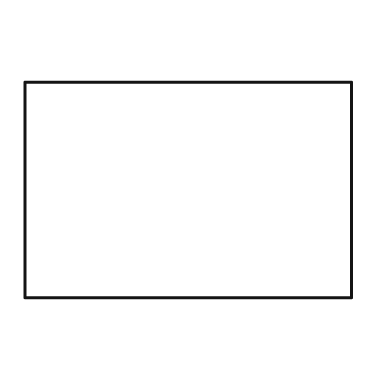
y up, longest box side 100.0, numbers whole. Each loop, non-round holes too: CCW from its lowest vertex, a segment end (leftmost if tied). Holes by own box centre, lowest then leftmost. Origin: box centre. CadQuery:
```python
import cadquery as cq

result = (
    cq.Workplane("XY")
    .moveTo(-50.0, -33.0)
    .lineTo(50.0, -33.0)
    .lineTo(50.0, 33.0)
    .lineTo(-50.0, 33.0)
    .close()
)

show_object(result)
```